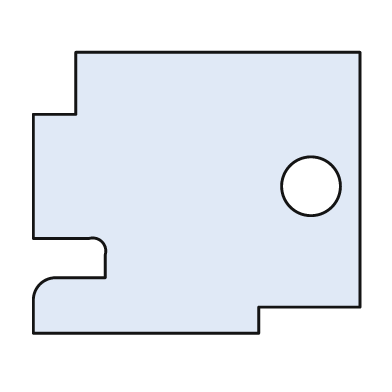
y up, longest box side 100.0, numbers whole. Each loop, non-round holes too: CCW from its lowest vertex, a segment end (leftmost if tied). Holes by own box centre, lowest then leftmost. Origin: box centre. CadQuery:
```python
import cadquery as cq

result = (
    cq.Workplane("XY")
    .moveTo(-50.0, -43.0)
    .lineTo(19.0, -43.0)
    .lineTo(19.0, -35.0)
    .lineTo(50.0, -35.0)
    .lineTo(50.0, 43.0)
    .lineTo(-37.0, 43.0)
    .lineTo(-37.0, 24.0)
    .lineTo(-50.0, 24.0)
    .lineTo(-50.0, -14.0)
    .lineTo(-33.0, -14.0)
    .threePointArc((-29.0, -15.0), (-28.0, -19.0))
    .lineTo(-28.0, -26.0)
    .lineTo(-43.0, -26.0)
    .threePointArc((-48.0, -28.0), (-50.0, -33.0))
    .close()
    .moveTo(35.0, 2.0)
    .circle(9.0)
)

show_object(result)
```